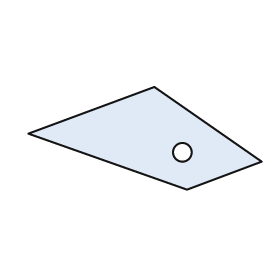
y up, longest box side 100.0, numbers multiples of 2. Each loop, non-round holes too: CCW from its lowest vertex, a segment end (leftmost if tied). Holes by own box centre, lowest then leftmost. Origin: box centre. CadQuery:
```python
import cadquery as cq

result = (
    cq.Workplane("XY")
    .moveTo(18.0, -22.0)
    .lineTo(50.0, -10.0)
    .lineTo(4.0, 22.0)
    .lineTo(-50.0, 2.0)
    .close()
    .moveTo(16.0, -6.0)
    .circle(4.0)
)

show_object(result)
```